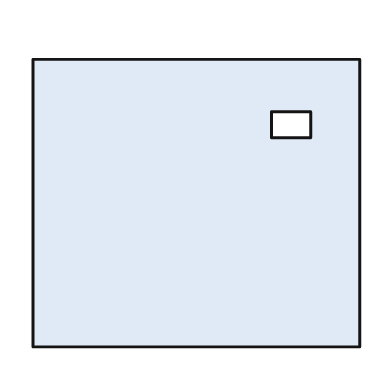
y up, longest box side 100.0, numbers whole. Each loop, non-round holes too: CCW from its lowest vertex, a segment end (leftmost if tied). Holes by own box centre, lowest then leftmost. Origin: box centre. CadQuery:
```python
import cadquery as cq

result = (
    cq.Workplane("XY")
    .moveTo(-50.0, -44.0)
    .lineTo(50.0, -44.0)
    .lineTo(50.0, 44.0)
    .lineTo(-50.0, 44.0)
    .close()
    .moveTo(23.0, 20.0)
    .lineTo(35.0, 20.0)
    .lineTo(35.0, 28.0)
    .lineTo(23.0, 28.0)
    .close()
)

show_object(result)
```